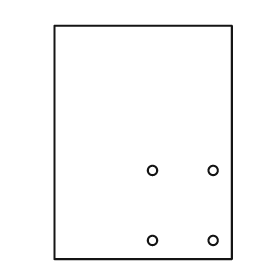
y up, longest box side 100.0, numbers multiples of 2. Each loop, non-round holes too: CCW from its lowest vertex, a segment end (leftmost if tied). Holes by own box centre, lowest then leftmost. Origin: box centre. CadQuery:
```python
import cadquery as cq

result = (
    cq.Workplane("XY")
    .moveTo(-38.0, -50.0)
    .lineTo(38.0, -50.0)
    .lineTo(38.0, 50.0)
    .lineTo(-38.0, 50.0)
    .close()
    .moveTo(4.0, -42.0)
    .circle(2.0)
    .moveTo(30.0, -42.0)
    .circle(2.0)
    .moveTo(4.0, -12.0)
    .circle(2.0)
    .moveTo(30.0, -12.0)
    .circle(2.0)
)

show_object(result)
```